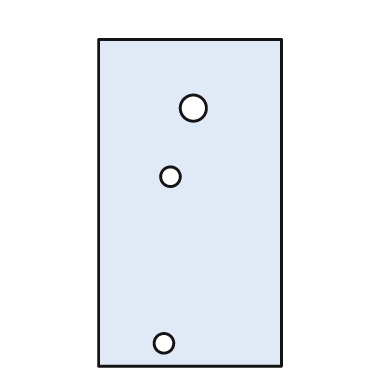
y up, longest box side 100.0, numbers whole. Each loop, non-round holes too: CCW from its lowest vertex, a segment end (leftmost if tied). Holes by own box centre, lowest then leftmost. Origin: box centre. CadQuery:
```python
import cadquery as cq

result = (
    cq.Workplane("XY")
    .moveTo(-28.0, -50.0)
    .lineTo(28.0, -50.0)
    .lineTo(28.0, 50.0)
    .lineTo(-28.0, 50.0)
    .close()
    .moveTo(-8.0, -43.0)
    .circle(3.0)
    .moveTo(-6.0, 8.0)
    .circle(3.0)
    .moveTo(1.0, 29.0)
    .circle(4.0)
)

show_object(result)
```